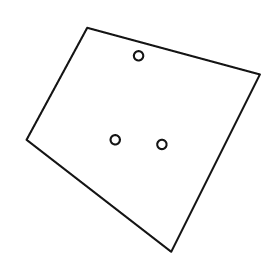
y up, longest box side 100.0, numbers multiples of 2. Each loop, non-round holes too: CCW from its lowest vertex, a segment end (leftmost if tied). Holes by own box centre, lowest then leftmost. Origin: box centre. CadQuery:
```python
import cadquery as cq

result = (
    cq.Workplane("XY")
    .moveTo(12.0, -48.0)
    .lineTo(50.0, 28.0)
    .lineTo(-24.0, 48.0)
    .lineTo(-50.0, 0.0)
    .close()
    .moveTo(8.0, -2.0)
    .circle(2.0)
    .moveTo(-12.0, 0.0)
    .circle(2.0)
    .moveTo(-2.0, 36.0)
    .circle(2.0)
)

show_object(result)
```